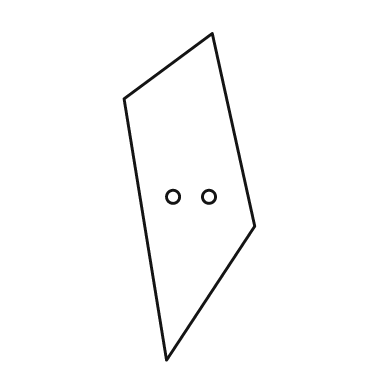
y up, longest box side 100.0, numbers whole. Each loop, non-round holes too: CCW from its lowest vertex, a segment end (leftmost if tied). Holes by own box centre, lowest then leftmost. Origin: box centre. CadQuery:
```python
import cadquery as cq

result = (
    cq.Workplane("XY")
    .moveTo(-7.0, -50.0)
    .lineTo(20.0, -9.0)
    .lineTo(7.0, 50.0)
    .lineTo(-20.0, 30.0)
    .close()
    .moveTo(-5.0, 0.0)
    .circle(2.0)
    .moveTo(6.0, 0.0)
    .circle(2.0)
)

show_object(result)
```